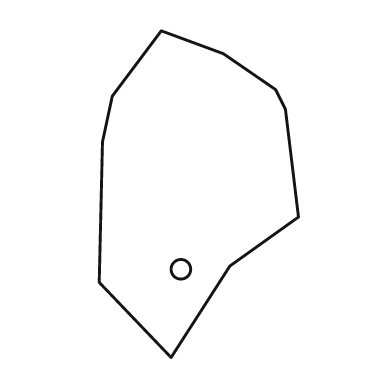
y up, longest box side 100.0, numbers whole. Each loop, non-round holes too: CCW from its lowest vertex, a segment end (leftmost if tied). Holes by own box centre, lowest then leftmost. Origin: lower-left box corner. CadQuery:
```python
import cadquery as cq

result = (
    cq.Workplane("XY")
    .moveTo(22.0, 0.0)
    .lineTo(40.0, 28.0)
    .lineTo(61.0, 43.0)
    .lineTo(57.0, 76.0)
    .lineTo(54.0, 82.0)
    .lineTo(38.0, 93.0)
    .lineTo(19.0, 100.0)
    .lineTo(4.0, 80.0)
    .lineTo(1.0, 66.0)
    .lineTo(0.0, 23.0)
    .close()
    .moveTo(25.0, 27.0)
    .circle(3.0)
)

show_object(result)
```